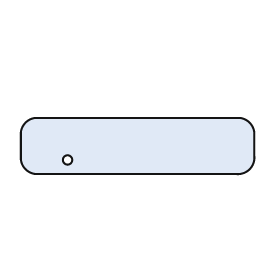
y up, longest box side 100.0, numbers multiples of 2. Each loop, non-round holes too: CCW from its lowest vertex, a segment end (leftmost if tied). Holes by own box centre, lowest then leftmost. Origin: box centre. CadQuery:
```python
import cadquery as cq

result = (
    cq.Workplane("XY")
    .moveTo(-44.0, -12.0)
    .lineTo(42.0, -12.0)
    .threePointArc((48.0, -10.0), (50.0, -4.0))
    .lineTo(50.0, 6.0)
    .threePointArc((48.0, 10.0), (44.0, 12.0))
    .lineTo(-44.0, 12.0)
    .threePointArc((-48.0, 10.0), (-50.0, 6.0))
    .lineTo(-50.0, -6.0)
    .threePointArc((-48.0, -10.0), (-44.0, -12.0))
    .close()
    .moveTo(-30.0, -6.0)
    .circle(2.0)
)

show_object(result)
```